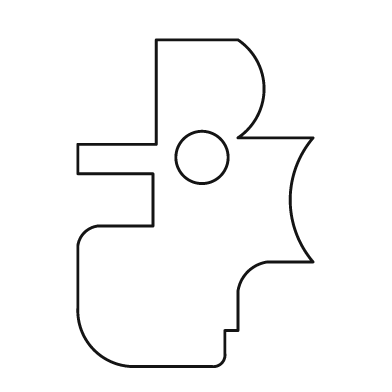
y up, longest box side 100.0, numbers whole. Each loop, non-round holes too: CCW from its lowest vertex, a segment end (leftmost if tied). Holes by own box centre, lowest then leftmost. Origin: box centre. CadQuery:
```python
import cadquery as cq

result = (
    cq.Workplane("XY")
    .moveTo(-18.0, -50.0)
    .lineTo(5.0, -50.0)
    .threePointArc((8.0, -49.0), (9.0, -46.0))
    .lineTo(9.0, -39.0)
    .lineTo(13.0, -39.0)
    .lineTo(13.0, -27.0)
    .threePointArc((16.0, -21.0), (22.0, -18.0))
    .lineTo(36.0, -18.0)
    .threePointArc((29.0, 1.0), (36.0, 20.0))
    .lineTo(13.0, 20.0)
    .threePointArc((21.0, 35.0), (13.0, 50.0))
    .lineTo(-12.0, 50.0)
    .lineTo(-12.0, 18.0)
    .lineTo(-36.0, 18.0)
    .lineTo(-36.0, 9.0)
    .lineTo(-13.0, 9.0)
    .lineTo(-13.0, -7.0)
    .lineTo(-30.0, -7.0)
    .threePointArc((-34.0, -9.0), (-36.0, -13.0))
    .lineTo(-36.0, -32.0)
    .threePointArc((-31.0, -45.0), (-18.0, -50.0))
    .close()
    .moveTo(2.0, 14.0)
    .circle(8.0)
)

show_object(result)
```